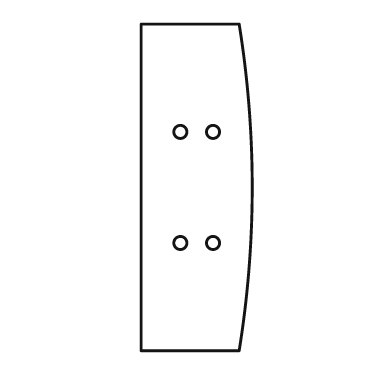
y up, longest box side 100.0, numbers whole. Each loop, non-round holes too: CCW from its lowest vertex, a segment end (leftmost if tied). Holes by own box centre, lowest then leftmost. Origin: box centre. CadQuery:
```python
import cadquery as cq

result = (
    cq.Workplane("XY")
    .moveTo(-17.0, -50.0)
    .lineTo(13.0, -50.0)
    .threePointArc((17.0, 0.0), (13.0, 50.0))
    .lineTo(-17.0, 50.0)
    .close()
    .moveTo(-5.0, -17.0)
    .circle(2.0)
    .moveTo(5.0, -17.0)
    .circle(2.0)
    .moveTo(-5.0, 17.0)
    .circle(2.0)
    .moveTo(5.0, 17.0)
    .circle(2.0)
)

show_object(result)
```